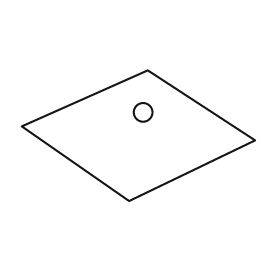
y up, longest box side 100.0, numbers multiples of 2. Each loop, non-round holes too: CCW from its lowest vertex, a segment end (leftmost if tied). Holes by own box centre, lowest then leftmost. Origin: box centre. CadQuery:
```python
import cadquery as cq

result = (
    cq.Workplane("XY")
    .moveTo(-4.0, -28.0)
    .lineTo(50.0, -2.0)
    .lineTo(4.0, 28.0)
    .lineTo(-50.0, 4.0)
    .close()
    .moveTo(2.0, 10.0)
    .circle(4.0)
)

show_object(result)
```